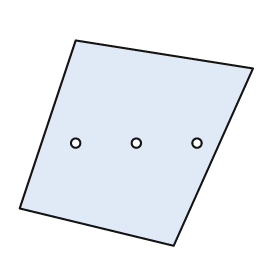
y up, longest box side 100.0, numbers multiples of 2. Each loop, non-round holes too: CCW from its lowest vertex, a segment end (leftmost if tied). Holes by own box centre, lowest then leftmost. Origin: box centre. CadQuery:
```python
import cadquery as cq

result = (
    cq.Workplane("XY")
    .moveTo(16.0, -44.0)
    .lineTo(50.0, 32.0)
    .lineTo(-26.0, 44.0)
    .lineTo(-50.0, -28.0)
    .close()
    .moveTo(-26.0, 0.0)
    .circle(2.0)
    .moveTo(0.0, 0.0)
    .circle(2.0)
    .moveTo(26.0, 0.0)
    .circle(2.0)
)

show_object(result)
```